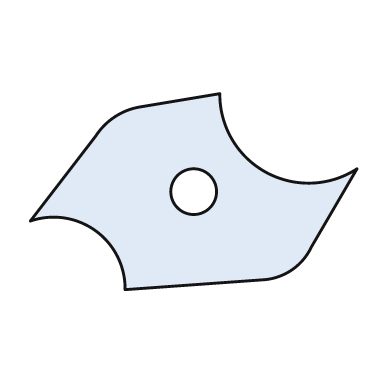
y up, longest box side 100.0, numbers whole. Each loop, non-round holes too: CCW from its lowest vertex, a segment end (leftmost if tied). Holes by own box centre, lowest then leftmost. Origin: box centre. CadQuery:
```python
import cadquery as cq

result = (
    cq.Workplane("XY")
    .moveTo(-21.0, -30.0)
    .lineTo(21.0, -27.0)
    .threePointArc((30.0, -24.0), (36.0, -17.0))
    .lineTo(50.0, 7.0)
    .threePointArc((22.0, 6.0), (8.0, 30.0))
    .lineTo(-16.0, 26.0)
    .threePointArc((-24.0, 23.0), (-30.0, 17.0))
    .lineTo(-50.0, -9.0)
    .threePointArc((-30.0, -12.0), (-21.0, -30.0))
    .close()
    .moveTo(0.0, 0.0)
    .circle(7.0)
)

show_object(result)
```